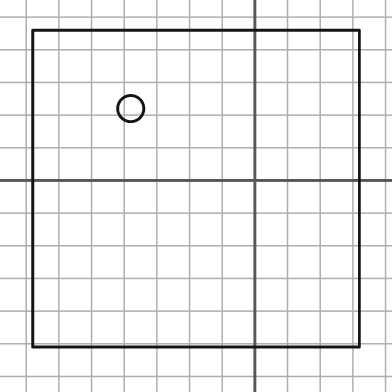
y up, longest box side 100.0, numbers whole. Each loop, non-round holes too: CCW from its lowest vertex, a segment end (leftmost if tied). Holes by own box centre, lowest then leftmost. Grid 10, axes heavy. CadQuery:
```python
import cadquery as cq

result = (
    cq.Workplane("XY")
    .moveTo(-68.0, -51.0)
    .lineTo(32.0, -51.0)
    .lineTo(32.0, 46.0)
    .lineTo(-68.0, 46.0)
    .close()
    .moveTo(-38.0, 22.0)
    .circle(4.0)
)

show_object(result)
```